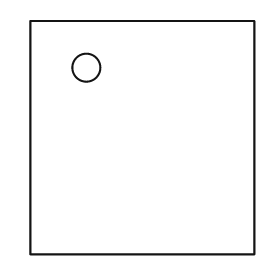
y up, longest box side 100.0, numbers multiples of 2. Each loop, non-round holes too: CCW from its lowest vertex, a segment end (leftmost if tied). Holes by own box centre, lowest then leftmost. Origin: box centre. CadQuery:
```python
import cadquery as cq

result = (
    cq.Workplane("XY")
    .moveTo(-48.0, -50.0)
    .lineTo(48.0, -50.0)
    .lineTo(48.0, 50.0)
    .lineTo(-48.0, 50.0)
    .close()
    .moveTo(-24.0, 30.0)
    .circle(6.0)
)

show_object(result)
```